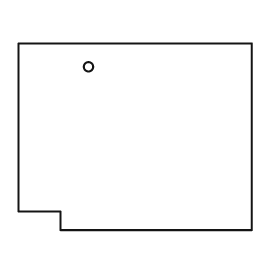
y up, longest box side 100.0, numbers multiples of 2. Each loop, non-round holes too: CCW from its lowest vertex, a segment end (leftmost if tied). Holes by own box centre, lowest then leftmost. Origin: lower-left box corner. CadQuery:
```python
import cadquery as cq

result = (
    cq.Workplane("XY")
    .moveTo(18.0, 0.0)
    .lineTo(100.0, 0.0)
    .lineTo(100.0, 80.0)
    .lineTo(0.0, 80.0)
    .lineTo(0.0, 8.0)
    .lineTo(18.0, 8.0)
    .close()
    .moveTo(30.0, 70.0)
    .circle(2.0)
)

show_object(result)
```